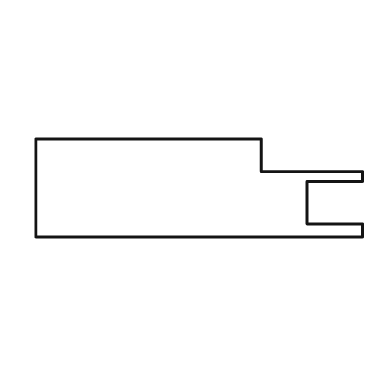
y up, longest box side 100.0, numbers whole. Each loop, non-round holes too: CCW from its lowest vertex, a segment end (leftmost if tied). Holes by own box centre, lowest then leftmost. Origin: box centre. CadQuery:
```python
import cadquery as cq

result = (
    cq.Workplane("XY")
    .moveTo(-50.0, -15.0)
    .lineTo(50.0, -15.0)
    .lineTo(50.0, -11.0)
    .lineTo(33.0, -11.0)
    .lineTo(33.0, 2.0)
    .lineTo(50.0, 2.0)
    .lineTo(50.0, 5.0)
    .lineTo(19.0, 5.0)
    .lineTo(19.0, 15.0)
    .lineTo(-50.0, 15.0)
    .close()
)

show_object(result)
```